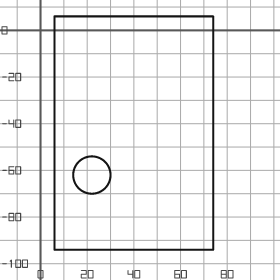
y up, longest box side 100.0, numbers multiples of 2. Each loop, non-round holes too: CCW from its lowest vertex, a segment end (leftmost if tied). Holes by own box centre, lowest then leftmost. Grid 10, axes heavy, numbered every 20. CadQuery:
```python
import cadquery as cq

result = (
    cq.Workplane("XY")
    .moveTo(6.0, -94.0)
    .lineTo(74.0, -94.0)
    .lineTo(74.0, 6.0)
    .lineTo(6.0, 6.0)
    .close()
    .moveTo(22.0, -62.0)
    .circle(8.0)
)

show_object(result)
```